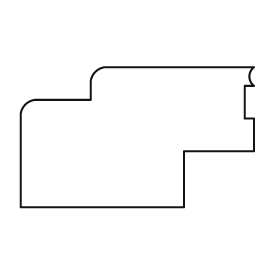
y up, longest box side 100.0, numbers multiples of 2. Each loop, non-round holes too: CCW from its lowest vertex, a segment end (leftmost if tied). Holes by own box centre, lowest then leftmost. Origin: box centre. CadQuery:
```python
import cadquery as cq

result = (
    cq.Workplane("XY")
    .moveTo(-50.0, -30.0)
    .lineTo(20.0, -30.0)
    .lineTo(20.0, -6.0)
    .lineTo(50.0, -6.0)
    .lineTo(50.0, 8.0)
    .lineTo(46.0, 8.0)
    .lineTo(46.0, 22.0)
    .lineTo(50.0, 22.0)
    .threePointArc((48.0, 26.0), (50.0, 30.0))
    .lineTo(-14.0, 30.0)
    .threePointArc((-18.0, 28.0), (-20.0, 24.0))
    .lineTo(-20.0, 16.0)
    .lineTo(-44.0, 16.0)
    .threePointArc((-48.0, 14.0), (-50.0, 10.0))
    .close()
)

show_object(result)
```